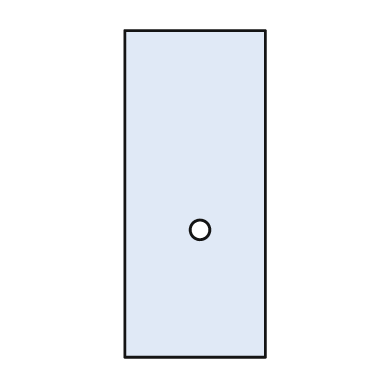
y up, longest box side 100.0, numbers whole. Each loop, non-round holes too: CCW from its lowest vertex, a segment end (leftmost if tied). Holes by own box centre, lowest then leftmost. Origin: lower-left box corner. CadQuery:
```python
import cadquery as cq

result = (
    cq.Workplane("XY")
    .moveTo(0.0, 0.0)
    .lineTo(43.0, 0.0)
    .lineTo(43.0, 100.0)
    .lineTo(0.0, 100.0)
    .close()
    .moveTo(23.0, 39.0)
    .circle(3.0)
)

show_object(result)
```